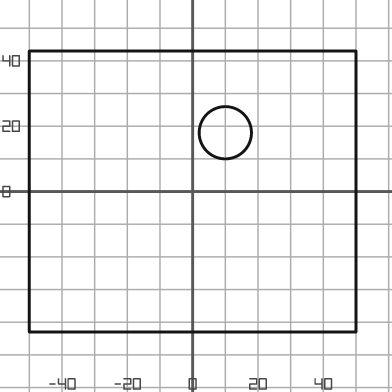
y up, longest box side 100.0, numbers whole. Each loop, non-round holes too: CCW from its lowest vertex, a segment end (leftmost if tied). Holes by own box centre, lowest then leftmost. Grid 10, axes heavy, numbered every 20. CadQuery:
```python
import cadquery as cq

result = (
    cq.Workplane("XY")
    .moveTo(-50.0, -43.0)
    .lineTo(50.0, -43.0)
    .lineTo(50.0, 43.0)
    .lineTo(-50.0, 43.0)
    .close()
    .moveTo(10.0, 18.0)
    .circle(8.0)
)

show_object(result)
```